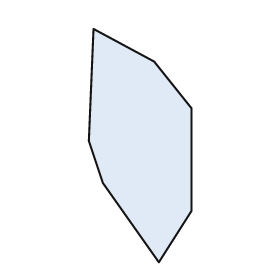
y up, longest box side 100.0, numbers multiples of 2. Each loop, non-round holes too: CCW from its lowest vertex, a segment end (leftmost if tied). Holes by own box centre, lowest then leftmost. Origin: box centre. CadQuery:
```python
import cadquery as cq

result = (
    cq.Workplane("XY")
    .moveTo(8.0, -50.0)
    .lineTo(22.0, -28.0)
    .lineTo(22.0, 16.0)
    .lineTo(6.0, 36.0)
    .lineTo(-20.0, 50.0)
    .lineTo(-22.0, 2.0)
    .lineTo(-16.0, -16.0)
    .close()
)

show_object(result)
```